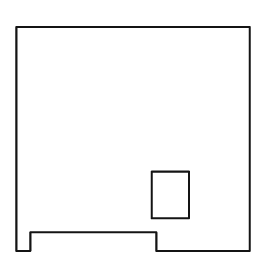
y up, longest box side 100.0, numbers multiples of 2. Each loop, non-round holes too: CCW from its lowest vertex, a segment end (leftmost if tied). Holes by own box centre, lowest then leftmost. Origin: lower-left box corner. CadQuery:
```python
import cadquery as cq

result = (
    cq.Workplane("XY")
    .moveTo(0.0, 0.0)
    .lineTo(6.0, 0.0)
    .lineTo(6.0, 8.0)
    .lineTo(60.0, 8.0)
    .lineTo(60.0, 0.0)
    .lineTo(100.0, 0.0)
    .lineTo(100.0, 96.0)
    .lineTo(0.0, 96.0)
    .close()
    .moveTo(58.0, 14.0)
    .lineTo(74.0, 14.0)
    .lineTo(74.0, 34.0)
    .lineTo(58.0, 34.0)
    .close()
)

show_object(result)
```